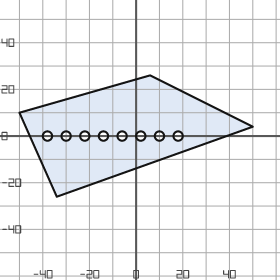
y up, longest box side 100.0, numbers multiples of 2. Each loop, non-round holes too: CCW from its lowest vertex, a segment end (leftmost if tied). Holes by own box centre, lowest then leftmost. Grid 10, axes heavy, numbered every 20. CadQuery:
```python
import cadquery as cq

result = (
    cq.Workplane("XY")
    .moveTo(-34.0, -26.0)
    .lineTo(50.0, 4.0)
    .lineTo(6.0, 26.0)
    .lineTo(-50.0, 10.0)
    .close()
    .moveTo(-38.0, 0.0)
    .circle(2.0)
    .moveTo(-30.0, 0.0)
    .circle(2.0)
    .moveTo(-22.0, 0.0)
    .circle(2.0)
    .moveTo(-14.0, 0.0)
    .circle(2.0)
    .moveTo(-6.0, 0.0)
    .circle(2.0)
    .moveTo(2.0, 0.0)
    .circle(2.0)
    .moveTo(10.0, 0.0)
    .circle(2.0)
    .moveTo(18.0, 0.0)
    .circle(2.0)
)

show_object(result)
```